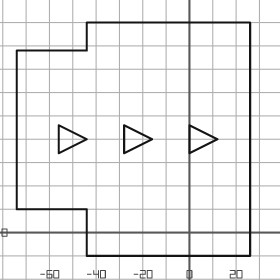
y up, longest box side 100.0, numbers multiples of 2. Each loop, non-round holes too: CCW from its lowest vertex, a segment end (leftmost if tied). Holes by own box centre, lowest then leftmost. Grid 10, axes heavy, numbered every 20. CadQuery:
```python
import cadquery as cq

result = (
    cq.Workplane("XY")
    .moveTo(-44.0, -10.0)
    .lineTo(26.0, -10.0)
    .lineTo(26.0, 90.0)
    .lineTo(-44.0, 90.0)
    .lineTo(-44.0, 78.0)
    .lineTo(-74.0, 78.0)
    .lineTo(-74.0, 10.0)
    .lineTo(-44.0, 10.0)
    .close()
    .moveTo(-56.0, 34.0)
    .lineTo(-44.0, 40.0)
    .lineTo(-56.0, 46.0)
    .close()
    .moveTo(-28.0, 34.0)
    .lineTo(-16.0, 40.0)
    .lineTo(-28.0, 46.0)
    .close()
    .moveTo(0.0, 34.0)
    .lineTo(12.0, 40.0)
    .lineTo(0.0, 46.0)
    .close()
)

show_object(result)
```